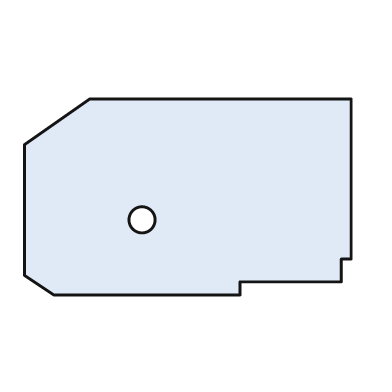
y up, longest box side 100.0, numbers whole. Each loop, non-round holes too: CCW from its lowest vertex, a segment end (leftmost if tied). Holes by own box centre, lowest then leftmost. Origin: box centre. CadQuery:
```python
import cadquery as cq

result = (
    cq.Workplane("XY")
    .moveTo(-41.0, -30.0)
    .lineTo(16.0, -30.0)
    .lineTo(16.0, -26.0)
    .lineTo(47.0, -26.0)
    .lineTo(47.0, -19.0)
    .lineTo(50.0, -19.0)
    .lineTo(50.0, 30.0)
    .lineTo(-30.0, 30.0)
    .lineTo(-50.0, 16.0)
    .lineTo(-50.0, -24.0)
    .close()
    .moveTo(-14.0, -7.0)
    .circle(4.0)
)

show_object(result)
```